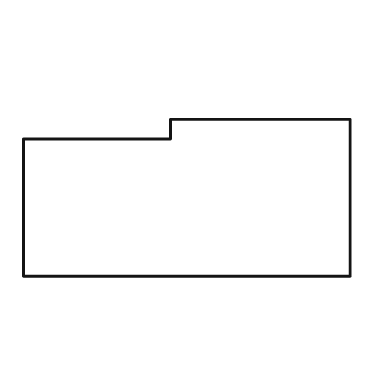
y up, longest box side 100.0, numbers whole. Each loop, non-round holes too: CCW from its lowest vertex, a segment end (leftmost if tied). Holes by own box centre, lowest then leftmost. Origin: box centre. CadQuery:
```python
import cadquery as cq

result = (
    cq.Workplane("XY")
    .moveTo(-50.0, -24.0)
    .lineTo(50.0, -24.0)
    .lineTo(50.0, 24.0)
    .lineTo(-5.0, 24.0)
    .lineTo(-5.0, 18.0)
    .lineTo(-50.0, 18.0)
    .close()
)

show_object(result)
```